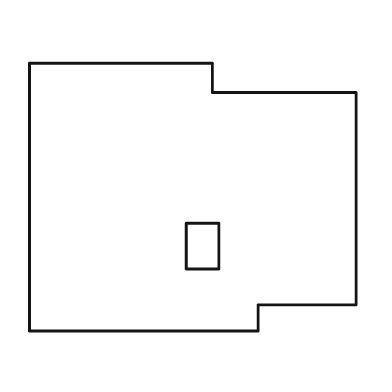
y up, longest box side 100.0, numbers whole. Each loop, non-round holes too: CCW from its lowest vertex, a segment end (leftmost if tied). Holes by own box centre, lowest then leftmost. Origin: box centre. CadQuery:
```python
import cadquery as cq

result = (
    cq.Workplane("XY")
    .moveTo(-50.0, -41.0)
    .lineTo(20.0, -41.0)
    .lineTo(20.0, -33.0)
    .lineTo(50.0, -33.0)
    .lineTo(50.0, 32.0)
    .lineTo(6.0, 32.0)
    .lineTo(6.0, 41.0)
    .lineTo(-50.0, 41.0)
    .close()
    .moveTo(-2.0, -22.0)
    .lineTo(8.0, -22.0)
    .lineTo(8.0, -8.0)
    .lineTo(-2.0, -8.0)
    .close()
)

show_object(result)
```